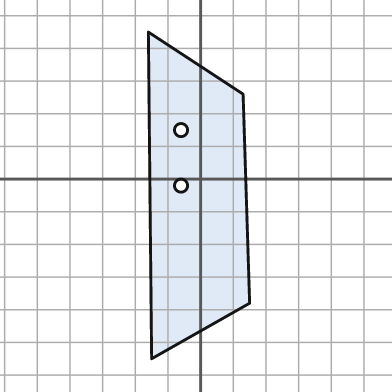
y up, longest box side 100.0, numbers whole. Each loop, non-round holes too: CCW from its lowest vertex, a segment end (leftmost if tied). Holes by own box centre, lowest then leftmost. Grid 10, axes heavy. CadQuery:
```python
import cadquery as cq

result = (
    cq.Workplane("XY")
    .moveTo(-15.0, -55.0)
    .lineTo(15.0, -38.0)
    .lineTo(13.0, 26.0)
    .lineTo(-16.0, 45.0)
    .close()
    .moveTo(-6.0, -2.0)
    .circle(2.0)
    .moveTo(-6.0, 15.0)
    .circle(2.0)
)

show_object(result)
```